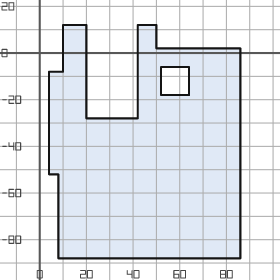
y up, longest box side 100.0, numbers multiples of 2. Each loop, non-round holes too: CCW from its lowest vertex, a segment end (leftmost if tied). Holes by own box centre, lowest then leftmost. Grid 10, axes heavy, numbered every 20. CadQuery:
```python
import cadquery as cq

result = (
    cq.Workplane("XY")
    .moveTo(8.0, -88.0)
    .lineTo(86.0, -88.0)
    .lineTo(86.0, 2.0)
    .lineTo(50.0, 2.0)
    .lineTo(50.0, 12.0)
    .lineTo(42.0, 12.0)
    .lineTo(42.0, -28.0)
    .lineTo(20.0, -28.0)
    .lineTo(20.0, 12.0)
    .lineTo(10.0, 12.0)
    .lineTo(10.0, -8.0)
    .lineTo(4.0, -8.0)
    .lineTo(4.0, -52.0)
    .lineTo(8.0, -52.0)
    .close()
    .moveTo(52.0, -18.0)
    .lineTo(64.0, -18.0)
    .lineTo(64.0, -6.0)
    .lineTo(52.0, -6.0)
    .close()
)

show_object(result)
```